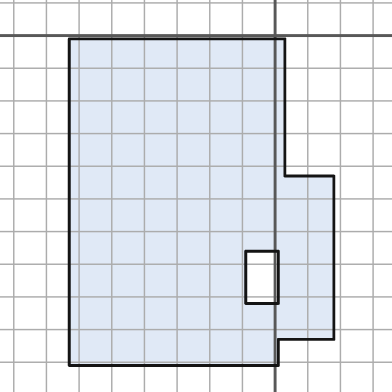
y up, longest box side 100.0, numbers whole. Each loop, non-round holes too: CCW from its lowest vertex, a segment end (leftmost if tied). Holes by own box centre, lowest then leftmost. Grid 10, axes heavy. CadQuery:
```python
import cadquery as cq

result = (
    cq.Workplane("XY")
    .moveTo(-63.0, -101.0)
    .lineTo(1.0, -101.0)
    .lineTo(1.0, -93.0)
    .lineTo(18.0, -93.0)
    .lineTo(18.0, -43.0)
    .lineTo(3.0, -43.0)
    .lineTo(3.0, -1.0)
    .lineTo(-63.0, -1.0)
    .close()
    .moveTo(-9.0, -82.0)
    .lineTo(1.0, -82.0)
    .lineTo(1.0, -66.0)
    .lineTo(-9.0, -66.0)
    .close()
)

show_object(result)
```